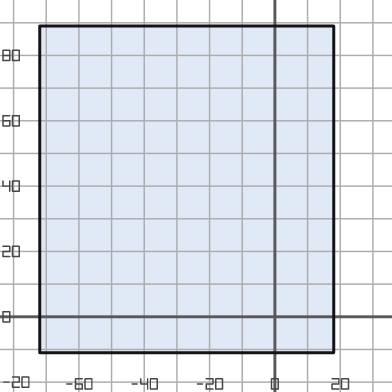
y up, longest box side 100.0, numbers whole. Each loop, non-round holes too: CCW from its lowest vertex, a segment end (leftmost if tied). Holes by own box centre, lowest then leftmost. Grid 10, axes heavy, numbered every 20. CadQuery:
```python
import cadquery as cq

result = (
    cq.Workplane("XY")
    .moveTo(-72.0, -11.0)
    .lineTo(18.0, -11.0)
    .lineTo(18.0, 89.0)
    .lineTo(-72.0, 89.0)
    .close()
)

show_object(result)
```